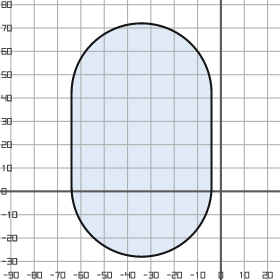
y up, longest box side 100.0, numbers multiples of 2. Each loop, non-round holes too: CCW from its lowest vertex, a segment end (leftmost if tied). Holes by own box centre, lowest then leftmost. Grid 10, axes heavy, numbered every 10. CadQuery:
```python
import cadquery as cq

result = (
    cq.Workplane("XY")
    .moveTo(-64.0, 2.0)
    .threePointArc((-34.0, -28.0), (-4.0, 2.0))
    .lineTo(-4.0, 42.0)
    .threePointArc((-34.0, 72.0), (-64.0, 42.0))
    .close()
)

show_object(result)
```